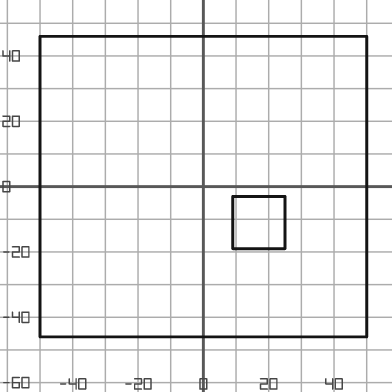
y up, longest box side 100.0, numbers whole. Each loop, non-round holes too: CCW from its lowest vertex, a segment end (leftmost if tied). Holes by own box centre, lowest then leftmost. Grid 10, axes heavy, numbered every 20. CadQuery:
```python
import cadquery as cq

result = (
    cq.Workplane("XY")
    .moveTo(-50.0, -46.0)
    .lineTo(50.0, -46.0)
    .lineTo(50.0, 46.0)
    .lineTo(-50.0, 46.0)
    .close()
    .moveTo(9.0, -19.0)
    .lineTo(25.0, -19.0)
    .lineTo(25.0, -3.0)
    .lineTo(9.0, -3.0)
    .close()
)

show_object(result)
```